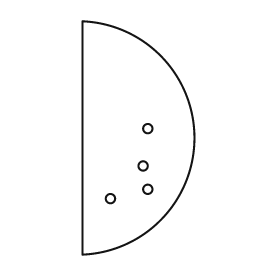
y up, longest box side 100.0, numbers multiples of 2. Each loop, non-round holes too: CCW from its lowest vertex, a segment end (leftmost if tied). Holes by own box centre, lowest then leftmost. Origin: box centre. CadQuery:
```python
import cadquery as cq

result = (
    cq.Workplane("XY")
    .moveTo(-24.0, -50.0)
    .threePointArc((24.0, 0.0), (-24.0, 50.0))
    .close()
    .moveTo(-12.0, -26.0)
    .circle(2.0)
    .moveTo(4.0, -22.0)
    .circle(2.0)
    .moveTo(2.0, -12.0)
    .circle(2.0)
    .moveTo(4.0, 4.0)
    .circle(2.0)
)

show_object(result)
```